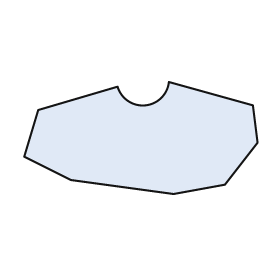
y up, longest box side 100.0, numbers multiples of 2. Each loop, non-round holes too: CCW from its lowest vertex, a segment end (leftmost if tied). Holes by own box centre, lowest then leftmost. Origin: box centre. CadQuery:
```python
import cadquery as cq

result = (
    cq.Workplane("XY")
    .moveTo(14.0, -24.0)
    .lineTo(36.0, -20.0)
    .lineTo(50.0, -2.0)
    .lineTo(48.0, 14.0)
    .lineTo(12.0, 24.0)
    .threePointArc((2.0, 14.0), (-10.0, 22.0))
    .lineTo(-44.0, 12.0)
    .lineTo(-50.0, -8.0)
    .lineTo(-30.0, -18.0)
    .close()
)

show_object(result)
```